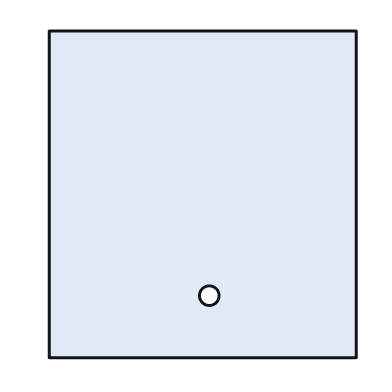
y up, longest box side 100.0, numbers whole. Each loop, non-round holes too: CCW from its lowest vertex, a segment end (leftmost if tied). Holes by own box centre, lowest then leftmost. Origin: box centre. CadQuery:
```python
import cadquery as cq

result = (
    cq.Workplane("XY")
    .moveTo(-47.0, -50.0)
    .lineTo(47.0, -50.0)
    .lineTo(47.0, 50.0)
    .lineTo(-47.0, 50.0)
    .close()
    .moveTo(2.0, -31.0)
    .circle(3.0)
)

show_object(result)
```